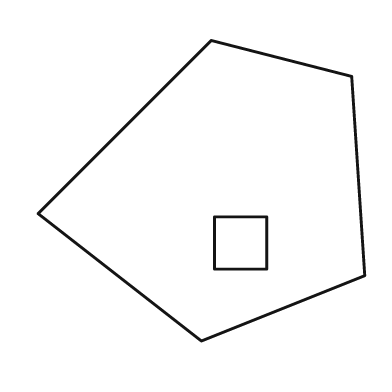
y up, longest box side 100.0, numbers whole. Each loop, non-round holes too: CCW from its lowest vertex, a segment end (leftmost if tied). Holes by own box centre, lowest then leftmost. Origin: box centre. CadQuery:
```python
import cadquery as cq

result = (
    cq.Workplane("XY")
    .moveTo(0.0, -46.0)
    .lineTo(50.0, -26.0)
    .lineTo(46.0, 35.0)
    .lineTo(3.0, 46.0)
    .lineTo(-50.0, -7.0)
    .close()
    .moveTo(4.0, -24.0)
    .lineTo(20.0, -24.0)
    .lineTo(20.0, -8.0)
    .lineTo(4.0, -8.0)
    .close()
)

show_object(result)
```